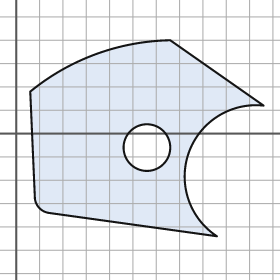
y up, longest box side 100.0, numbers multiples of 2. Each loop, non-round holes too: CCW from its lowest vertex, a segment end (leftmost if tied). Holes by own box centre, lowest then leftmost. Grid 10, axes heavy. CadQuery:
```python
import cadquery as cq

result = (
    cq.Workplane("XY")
    .moveTo(86.0, -44.0)
    .threePointArc((74.0, -8.0), (106.0, 12.0))
    .lineTo(66.0, 40.0)
    .threePointArc((34.0, 34.0), (6.0, 18.0))
    .lineTo(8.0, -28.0)
    .threePointArc((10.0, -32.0), (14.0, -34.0))
    .close()
    .moveTo(56.0, -6.0)
    .circle(10.0)
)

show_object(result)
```